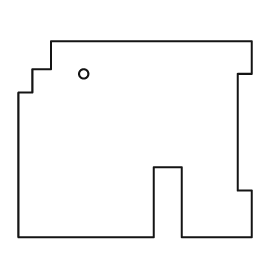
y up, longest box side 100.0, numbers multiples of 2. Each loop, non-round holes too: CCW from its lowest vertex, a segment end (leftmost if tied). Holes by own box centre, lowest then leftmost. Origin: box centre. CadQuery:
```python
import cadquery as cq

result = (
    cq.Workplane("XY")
    .moveTo(-50.0, -42.0)
    .lineTo(8.0, -42.0)
    .lineTo(8.0, -12.0)
    .lineTo(20.0, -12.0)
    .lineTo(20.0, -42.0)
    .lineTo(50.0, -42.0)
    .lineTo(50.0, -22.0)
    .lineTo(44.0, -22.0)
    .lineTo(44.0, 28.0)
    .lineTo(50.0, 28.0)
    .lineTo(50.0, 42.0)
    .lineTo(-36.0, 42.0)
    .lineTo(-36.0, 30.0)
    .lineTo(-44.0, 30.0)
    .lineTo(-44.0, 20.0)
    .lineTo(-50.0, 20.0)
    .close()
    .moveTo(-22.0, 28.0)
    .circle(2.0)
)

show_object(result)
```